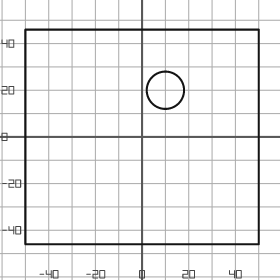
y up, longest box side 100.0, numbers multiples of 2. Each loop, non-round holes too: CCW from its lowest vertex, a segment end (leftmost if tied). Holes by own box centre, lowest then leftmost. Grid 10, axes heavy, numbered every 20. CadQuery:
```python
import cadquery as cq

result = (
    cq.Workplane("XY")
    .moveTo(-50.0, -46.0)
    .lineTo(50.0, -46.0)
    .lineTo(50.0, 46.0)
    .lineTo(-50.0, 46.0)
    .close()
    .moveTo(10.0, 20.0)
    .circle(8.0)
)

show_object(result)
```